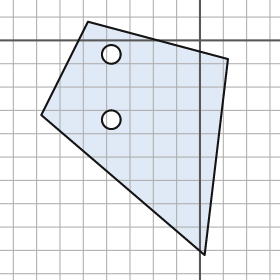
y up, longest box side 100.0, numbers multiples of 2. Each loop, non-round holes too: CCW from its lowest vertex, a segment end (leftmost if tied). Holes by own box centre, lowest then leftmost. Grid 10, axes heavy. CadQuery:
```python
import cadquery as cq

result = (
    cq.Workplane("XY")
    .moveTo(2.0, -92.0)
    .lineTo(12.0, -8.0)
    .lineTo(-48.0, 8.0)
    .lineTo(-68.0, -32.0)
    .close()
    .moveTo(-38.0, -34.0)
    .circle(4.0)
    .moveTo(-38.0, -6.0)
    .circle(4.0)
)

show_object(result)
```